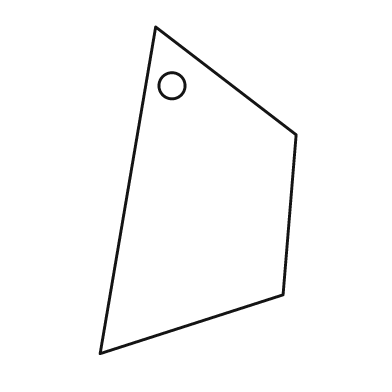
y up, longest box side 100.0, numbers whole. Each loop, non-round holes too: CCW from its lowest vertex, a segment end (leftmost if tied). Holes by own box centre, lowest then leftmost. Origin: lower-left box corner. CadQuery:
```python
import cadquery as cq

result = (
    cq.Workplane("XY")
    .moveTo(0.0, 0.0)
    .lineTo(56.0, 18.0)
    .lineTo(60.0, 67.0)
    .lineTo(17.0, 100.0)
    .close()
    .moveTo(22.0, 82.0)
    .circle(4.0)
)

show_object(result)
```